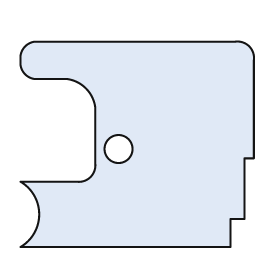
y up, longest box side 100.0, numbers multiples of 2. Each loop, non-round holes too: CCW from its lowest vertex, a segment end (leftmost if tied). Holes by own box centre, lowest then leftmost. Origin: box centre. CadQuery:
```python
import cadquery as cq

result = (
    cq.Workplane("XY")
    .moveTo(-50.0, -44.0)
    .lineTo(40.0, -44.0)
    .lineTo(40.0, -32.0)
    .lineTo(46.0, -32.0)
    .lineTo(46.0, -6.0)
    .lineTo(50.0, -6.0)
    .lineTo(50.0, 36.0)
    .threePointArc((48.0, 42.0), (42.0, 44.0))
    .lineTo(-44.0, 44.0)
    .threePointArc((-48.0, 42.0), (-50.0, 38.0))
    .lineTo(-50.0, 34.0)
    .threePointArc((-48.0, 30.0), (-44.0, 28.0))
    .lineTo(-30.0, 28.0)
    .threePointArc((-22.0, 24.0), (-18.0, 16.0))
    .lineTo(-18.0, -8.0)
    .threePointArc((-20.0, -14.0), (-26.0, -16.0))
    .lineTo(-50.0, -16.0)
    .threePointArc((-42.0, -30.0), (-50.0, -44.0))
    .close()
    .moveTo(-8.0, -2.0)
    .circle(6.0)
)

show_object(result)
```